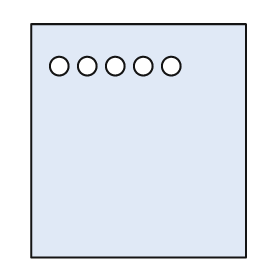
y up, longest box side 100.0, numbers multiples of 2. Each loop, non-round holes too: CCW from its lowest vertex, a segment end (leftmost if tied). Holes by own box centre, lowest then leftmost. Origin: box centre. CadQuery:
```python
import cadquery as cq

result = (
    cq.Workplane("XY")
    .moveTo(-46.0, -50.0)
    .lineTo(46.0, -50.0)
    .lineTo(46.0, 50.0)
    .lineTo(-46.0, 50.0)
    .close()
    .moveTo(-34.0, 32.0)
    .circle(4.0)
    .moveTo(-22.0, 32.0)
    .circle(4.0)
    .moveTo(-10.0, 32.0)
    .circle(4.0)
    .moveTo(2.0, 32.0)
    .circle(4.0)
    .moveTo(14.0, 32.0)
    .circle(4.0)
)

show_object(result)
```